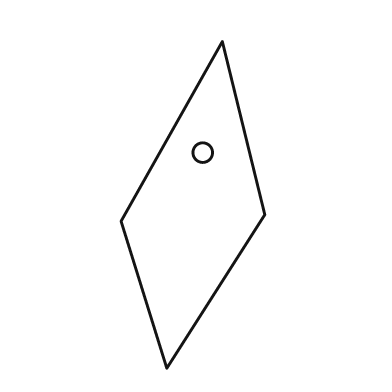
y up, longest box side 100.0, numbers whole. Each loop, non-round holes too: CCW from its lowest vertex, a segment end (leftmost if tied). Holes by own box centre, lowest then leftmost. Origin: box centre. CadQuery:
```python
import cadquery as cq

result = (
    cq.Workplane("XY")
    .moveTo(-8.0, -50.0)
    .lineTo(22.0, -3.0)
    .lineTo(9.0, 50.0)
    .lineTo(-22.0, -5.0)
    .close()
    .moveTo(3.0, 16.0)
    .circle(3.0)
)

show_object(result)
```